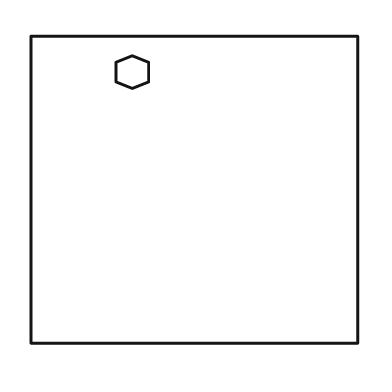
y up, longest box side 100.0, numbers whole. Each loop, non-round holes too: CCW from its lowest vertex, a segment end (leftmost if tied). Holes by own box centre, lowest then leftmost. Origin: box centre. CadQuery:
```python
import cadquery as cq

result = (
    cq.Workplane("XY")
    .moveTo(-50.0, -47.0)
    .lineTo(50.0, -47.0)
    .lineTo(50.0, 47.0)
    .lineTo(-50.0, 47.0)
    .close()
    .moveTo(-19.0, 31.0)
    .lineTo(-14.0, 33.0)
    .lineTo(-14.0, 39.0)
    .lineTo(-19.0, 41.0)
    .lineTo(-24.0, 39.0)
    .lineTo(-24.0, 33.0)
    .close()
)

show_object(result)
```